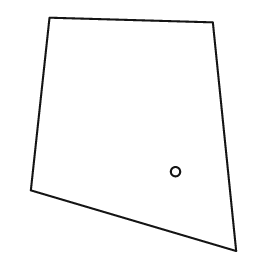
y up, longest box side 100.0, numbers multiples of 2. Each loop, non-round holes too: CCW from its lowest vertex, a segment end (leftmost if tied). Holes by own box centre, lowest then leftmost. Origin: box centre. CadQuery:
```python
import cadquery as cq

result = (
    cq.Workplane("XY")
    .moveTo(44.0, -50.0)
    .lineTo(34.0, 48.0)
    .lineTo(-36.0, 50.0)
    .lineTo(-44.0, -24.0)
    .close()
    .moveTo(18.0, -16.0)
    .circle(2.0)
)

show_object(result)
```